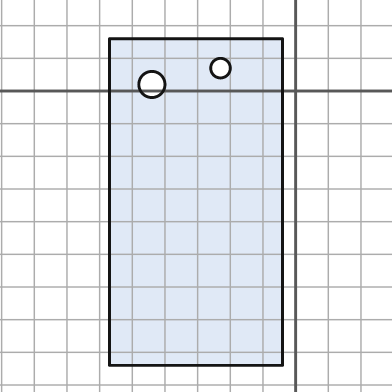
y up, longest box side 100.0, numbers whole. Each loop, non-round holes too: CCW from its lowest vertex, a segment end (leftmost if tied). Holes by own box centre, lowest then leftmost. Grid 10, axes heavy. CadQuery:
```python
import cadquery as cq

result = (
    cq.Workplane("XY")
    .moveTo(-57.0, -84.0)
    .lineTo(-4.0, -84.0)
    .lineTo(-4.0, 16.0)
    .lineTo(-57.0, 16.0)
    .close()
    .moveTo(-44.0, 2.0)
    .circle(4.0)
    .moveTo(-23.0, 7.0)
    .circle(3.0)
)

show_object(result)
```